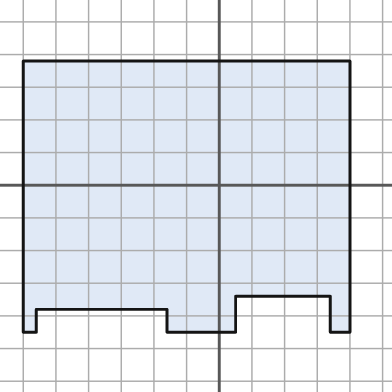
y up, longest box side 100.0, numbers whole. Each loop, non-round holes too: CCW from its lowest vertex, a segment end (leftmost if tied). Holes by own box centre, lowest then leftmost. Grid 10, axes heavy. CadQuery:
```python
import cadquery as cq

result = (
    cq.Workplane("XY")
    .moveTo(-60.0, -45.0)
    .lineTo(-56.0, -45.0)
    .lineTo(-56.0, -38.0)
    .lineTo(-16.0, -38.0)
    .lineTo(-16.0, -45.0)
    .lineTo(5.0, -45.0)
    .lineTo(5.0, -34.0)
    .lineTo(34.0, -34.0)
    .lineTo(34.0, -45.0)
    .lineTo(40.0, -45.0)
    .lineTo(40.0, 38.0)
    .lineTo(-60.0, 38.0)
    .close()
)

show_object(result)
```